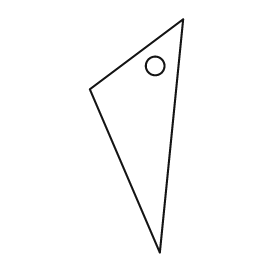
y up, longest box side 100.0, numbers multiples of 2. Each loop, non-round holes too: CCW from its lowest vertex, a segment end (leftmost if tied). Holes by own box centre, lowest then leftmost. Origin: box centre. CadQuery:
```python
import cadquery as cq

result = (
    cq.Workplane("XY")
    .moveTo(10.0, -50.0)
    .lineTo(20.0, 50.0)
    .lineTo(-20.0, 20.0)
    .close()
    .moveTo(8.0, 30.0)
    .circle(4.0)
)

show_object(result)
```